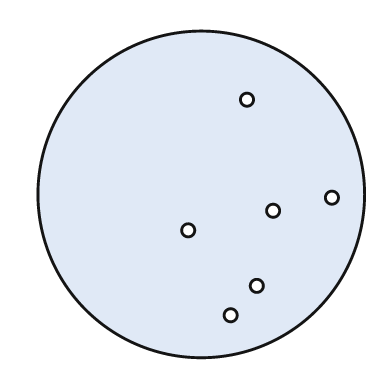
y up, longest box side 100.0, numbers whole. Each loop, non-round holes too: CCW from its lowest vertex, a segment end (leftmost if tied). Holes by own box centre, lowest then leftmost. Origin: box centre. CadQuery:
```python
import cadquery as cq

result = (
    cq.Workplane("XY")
    .moveTo(0.0, 0.0)
    .circle(50.0)
    .moveTo(9.0, -37.0)
    .circle(2.0)
    .moveTo(17.0, -28.0)
    .circle(2.0)
    .moveTo(-4.0, -11.0)
    .circle(2.0)
    .moveTo(22.0, -5.0)
    .circle(2.0)
    .moveTo(40.0, -1.0)
    .circle(2.0)
    .moveTo(14.0, 29.0)
    .circle(2.0)
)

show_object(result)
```